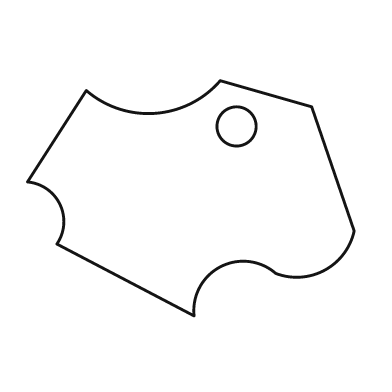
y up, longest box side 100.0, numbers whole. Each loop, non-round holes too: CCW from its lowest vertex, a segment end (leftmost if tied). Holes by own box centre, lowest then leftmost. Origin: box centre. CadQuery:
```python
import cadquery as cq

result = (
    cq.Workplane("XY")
    .moveTo(1.0, -36.0)
    .threePointArc((9.0, -21.0), (26.0, -23.0))
    .threePointArc((41.0, -22.0), (50.0, -10.0))
    .lineTo(37.0, 28.0)
    .lineTo(9.0, 36.0)
    .threePointArc((-11.0, 26.0), (-32.0, 33.0))
    .lineTo(-50.0, 5.0)
    .threePointArc((-40.0, -2.0), (-41.0, -14.0))
    .close()
    .moveTo(14.0, 22.0)
    .circle(6.0)
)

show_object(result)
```